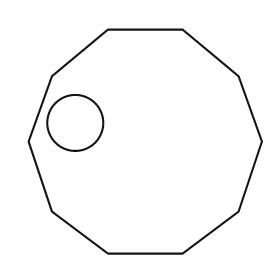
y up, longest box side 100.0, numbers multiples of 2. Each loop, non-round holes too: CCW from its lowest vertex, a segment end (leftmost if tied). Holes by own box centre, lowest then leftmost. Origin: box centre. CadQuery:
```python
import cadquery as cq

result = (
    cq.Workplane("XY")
    .moveTo(-16.0, -48.0)
    .lineTo(16.0, -48.0)
    .lineTo(40.0, -30.0)
    .lineTo(50.0, 0.0)
    .lineTo(40.0, 28.0)
    .lineTo(16.0, 48.0)
    .lineTo(-16.0, 48.0)
    .lineTo(-40.0, 28.0)
    .lineTo(-50.0, 0.0)
    .lineTo(-40.0, -30.0)
    .close()
    .moveTo(-30.0, 8.0)
    .circle(12.0)
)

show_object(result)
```